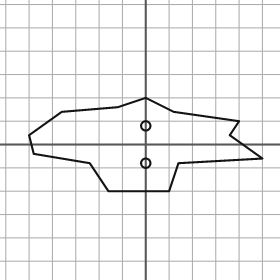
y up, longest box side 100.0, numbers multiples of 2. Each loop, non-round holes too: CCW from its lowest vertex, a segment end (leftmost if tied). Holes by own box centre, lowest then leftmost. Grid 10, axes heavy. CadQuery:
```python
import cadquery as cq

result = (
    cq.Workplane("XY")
    .moveTo(-16.0, -20.0)
    .lineTo(10.0, -20.0)
    .lineTo(14.0, -8.0)
    .lineTo(50.0, -6.0)
    .lineTo(36.0, 4.0)
    .lineTo(40.0, 10.0)
    .lineTo(12.0, 14.0)
    .lineTo(0.0, 20.0)
    .lineTo(-12.0, 16.0)
    .lineTo(-36.0, 14.0)
    .lineTo(-50.0, 4.0)
    .lineTo(-48.0, -4.0)
    .lineTo(-24.0, -8.0)
    .close()
    .moveTo(0.0, -8.0)
    .circle(2.0)
    .moveTo(0.0, 8.0)
    .circle(2.0)
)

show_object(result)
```